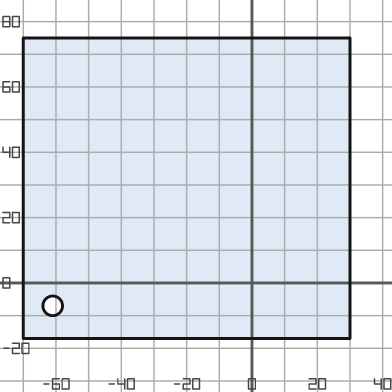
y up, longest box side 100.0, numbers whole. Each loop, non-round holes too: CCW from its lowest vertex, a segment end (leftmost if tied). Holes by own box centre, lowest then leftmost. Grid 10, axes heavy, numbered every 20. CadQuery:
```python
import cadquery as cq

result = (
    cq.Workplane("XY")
    .moveTo(-70.0, -17.0)
    .lineTo(30.0, -17.0)
    .lineTo(30.0, 75.0)
    .lineTo(-70.0, 75.0)
    .close()
    .moveTo(-61.0, -7.0)
    .circle(3.0)
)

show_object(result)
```